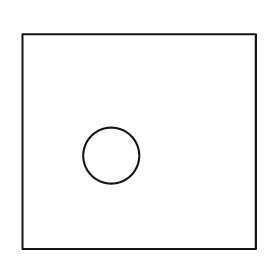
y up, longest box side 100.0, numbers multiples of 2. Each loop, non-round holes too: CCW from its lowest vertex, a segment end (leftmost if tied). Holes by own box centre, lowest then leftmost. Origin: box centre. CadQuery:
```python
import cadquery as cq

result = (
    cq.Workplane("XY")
    .moveTo(-50.0, -46.0)
    .lineTo(50.0, -46.0)
    .lineTo(50.0, 46.0)
    .lineTo(-50.0, 46.0)
    .close()
    .moveTo(-12.0, -6.0)
    .circle(12.0)
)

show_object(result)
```